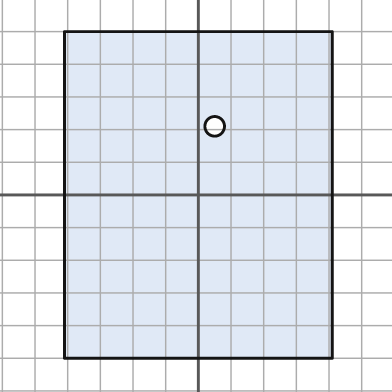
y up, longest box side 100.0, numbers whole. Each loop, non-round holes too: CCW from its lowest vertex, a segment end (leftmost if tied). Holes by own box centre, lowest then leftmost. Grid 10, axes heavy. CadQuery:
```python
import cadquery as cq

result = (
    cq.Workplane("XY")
    .moveTo(-41.0, -50.0)
    .lineTo(41.0, -50.0)
    .lineTo(41.0, 50.0)
    .lineTo(-41.0, 50.0)
    .close()
    .moveTo(5.0, 21.0)
    .circle(3.0)
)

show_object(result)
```